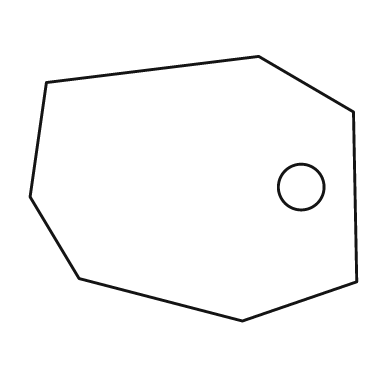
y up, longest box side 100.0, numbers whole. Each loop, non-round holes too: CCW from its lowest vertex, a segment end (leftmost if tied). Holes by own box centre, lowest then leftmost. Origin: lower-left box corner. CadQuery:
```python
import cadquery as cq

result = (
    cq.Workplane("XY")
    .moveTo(65.0, 0.0)
    .lineTo(100.0, 12.0)
    .lineTo(99.0, 64.0)
    .lineTo(70.0, 81.0)
    .lineTo(5.0, 73.0)
    .lineTo(0.0, 38.0)
    .lineTo(15.0, 13.0)
    .close()
    .moveTo(83.0, 41.0)
    .circle(7.0)
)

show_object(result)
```